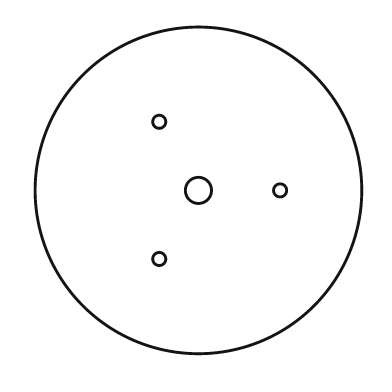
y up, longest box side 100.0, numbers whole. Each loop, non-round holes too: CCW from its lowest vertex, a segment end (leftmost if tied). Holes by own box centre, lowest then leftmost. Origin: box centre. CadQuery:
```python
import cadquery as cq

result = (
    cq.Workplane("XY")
    .moveTo(0.0, 0.0)
    .circle(50.0)
    .moveTo(-12.0, -21.0)
    .circle(2.0)
    .moveTo(0.0, 0.0)
    .circle(4.0)
    .moveTo(25.0, 0.0)
    .circle(2.0)
    .moveTo(-12.0, 21.0)
    .circle(2.0)
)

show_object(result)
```